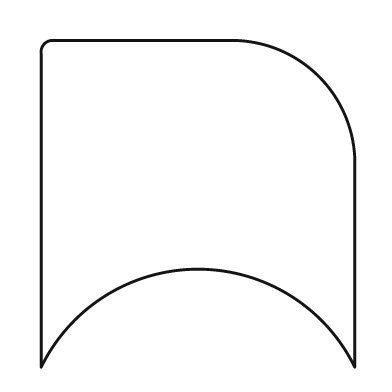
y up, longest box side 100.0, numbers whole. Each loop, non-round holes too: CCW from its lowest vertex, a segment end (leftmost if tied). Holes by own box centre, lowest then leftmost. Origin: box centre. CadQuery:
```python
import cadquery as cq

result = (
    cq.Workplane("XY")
    .moveTo(-48.0, -50.0)
    .threePointArc((0.0, -20.0), (48.0, -50.0))
    .lineTo(48.0, 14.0)
    .threePointArc((37.0, 39.0), (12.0, 50.0))
    .lineTo(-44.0, 50.0)
    .threePointArc((-47.0, 49.0), (-48.0, 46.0))
    .close()
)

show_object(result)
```